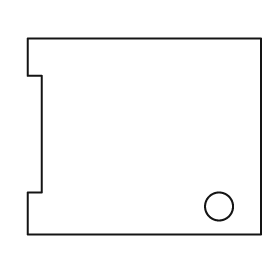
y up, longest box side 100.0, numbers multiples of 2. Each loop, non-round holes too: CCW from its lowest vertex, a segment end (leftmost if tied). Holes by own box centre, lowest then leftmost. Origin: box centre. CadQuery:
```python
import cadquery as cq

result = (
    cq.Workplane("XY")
    .moveTo(-50.0, -42.0)
    .lineTo(50.0, -42.0)
    .lineTo(50.0, 42.0)
    .lineTo(-50.0, 42.0)
    .lineTo(-50.0, 26.0)
    .lineTo(-44.0, 26.0)
    .lineTo(-44.0, -24.0)
    .lineTo(-50.0, -24.0)
    .close()
    .moveTo(32.0, -30.0)
    .circle(6.0)
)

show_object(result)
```